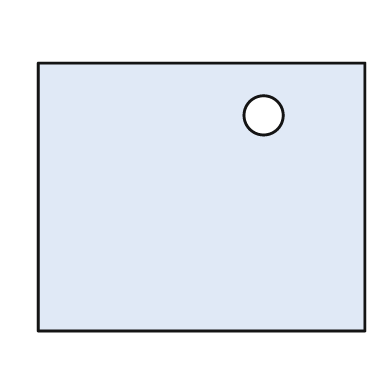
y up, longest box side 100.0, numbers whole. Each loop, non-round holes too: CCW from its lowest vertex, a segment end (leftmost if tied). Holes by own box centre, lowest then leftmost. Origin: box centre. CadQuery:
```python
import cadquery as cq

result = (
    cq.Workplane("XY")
    .moveTo(-50.0, -41.0)
    .lineTo(50.0, -41.0)
    .lineTo(50.0, 41.0)
    .lineTo(-50.0, 41.0)
    .close()
    .moveTo(19.0, 25.0)
    .circle(6.0)
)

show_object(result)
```